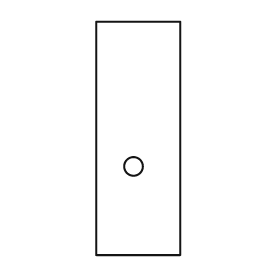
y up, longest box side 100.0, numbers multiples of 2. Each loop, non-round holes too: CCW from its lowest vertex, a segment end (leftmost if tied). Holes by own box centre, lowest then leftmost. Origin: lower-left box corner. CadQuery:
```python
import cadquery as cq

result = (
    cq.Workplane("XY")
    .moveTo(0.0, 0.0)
    .lineTo(36.0, 0.0)
    .lineTo(36.0, 100.0)
    .lineTo(0.0, 100.0)
    .close()
    .moveTo(16.0, 38.0)
    .circle(4.0)
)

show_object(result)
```